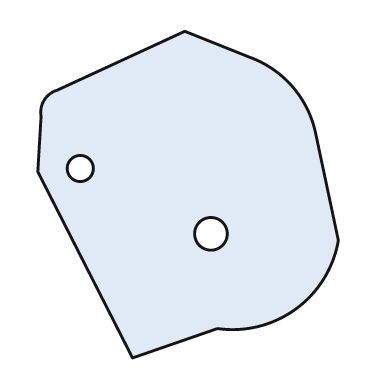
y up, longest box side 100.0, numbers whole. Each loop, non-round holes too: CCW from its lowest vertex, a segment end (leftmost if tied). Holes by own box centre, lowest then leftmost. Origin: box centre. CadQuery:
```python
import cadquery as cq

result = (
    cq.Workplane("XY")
    .moveTo(-17.0, -50.0)
    .lineTo(9.0, -41.0)
    .threePointArc((33.0, -35.0), (46.0, -14.0))
    .lineTo(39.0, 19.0)
    .threePointArc((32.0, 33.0), (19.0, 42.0))
    .lineTo(-1.0, 50.0)
    .lineTo(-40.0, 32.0)
    .threePointArc((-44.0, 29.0), (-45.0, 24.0))
    .lineTo(-46.0, 7.0)
    .close()
    .moveTo(7.0, -12.0)
    .circle(5.0)
    .moveTo(-33.0, 8.0)
    .circle(4.0)
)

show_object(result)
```